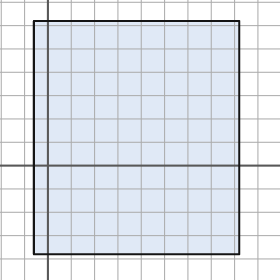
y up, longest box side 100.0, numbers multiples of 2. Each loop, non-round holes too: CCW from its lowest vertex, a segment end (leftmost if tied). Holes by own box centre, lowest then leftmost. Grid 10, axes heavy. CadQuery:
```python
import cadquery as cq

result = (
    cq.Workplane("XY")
    .moveTo(-6.0, -38.0)
    .lineTo(82.0, -38.0)
    .lineTo(82.0, 62.0)
    .lineTo(-6.0, 62.0)
    .close()
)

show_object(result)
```